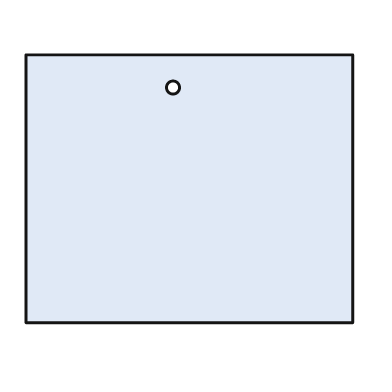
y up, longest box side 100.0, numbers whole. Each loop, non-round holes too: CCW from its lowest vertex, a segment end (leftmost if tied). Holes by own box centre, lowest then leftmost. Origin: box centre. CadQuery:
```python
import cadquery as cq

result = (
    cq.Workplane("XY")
    .moveTo(-50.0, -41.0)
    .lineTo(50.0, -41.0)
    .lineTo(50.0, 41.0)
    .lineTo(-50.0, 41.0)
    .close()
    .moveTo(-5.0, 31.0)
    .circle(2.0)
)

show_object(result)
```